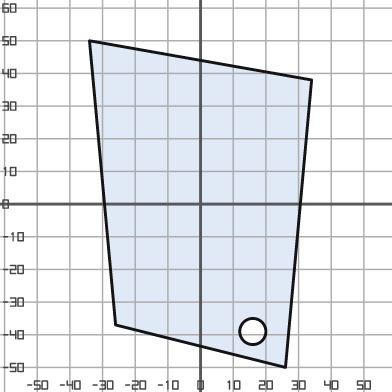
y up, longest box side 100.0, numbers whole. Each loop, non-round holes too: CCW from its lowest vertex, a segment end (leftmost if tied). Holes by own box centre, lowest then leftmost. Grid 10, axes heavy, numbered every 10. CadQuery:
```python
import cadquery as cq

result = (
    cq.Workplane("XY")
    .moveTo(26.0, -50.0)
    .lineTo(34.0, 38.0)
    .lineTo(-34.0, 50.0)
    .lineTo(-26.0, -37.0)
    .close()
    .moveTo(16.0, -39.0)
    .circle(4.0)
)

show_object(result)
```